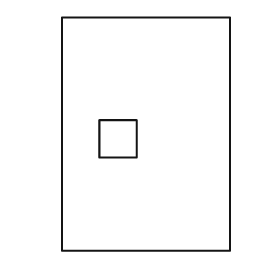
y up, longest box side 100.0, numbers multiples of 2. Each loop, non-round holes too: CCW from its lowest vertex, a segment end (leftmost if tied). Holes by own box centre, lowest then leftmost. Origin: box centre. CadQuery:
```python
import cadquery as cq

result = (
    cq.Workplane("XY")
    .moveTo(-36.0, -50.0)
    .lineTo(36.0, -50.0)
    .lineTo(36.0, 50.0)
    .lineTo(-36.0, 50.0)
    .close()
    .moveTo(-20.0, -10.0)
    .lineTo(-4.0, -10.0)
    .lineTo(-4.0, 6.0)
    .lineTo(-20.0, 6.0)
    .close()
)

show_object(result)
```